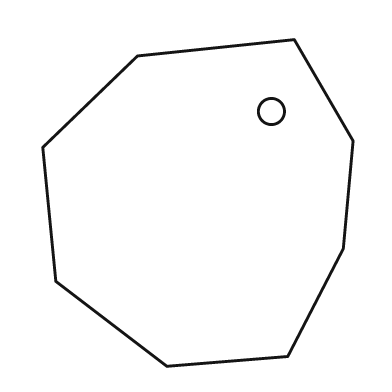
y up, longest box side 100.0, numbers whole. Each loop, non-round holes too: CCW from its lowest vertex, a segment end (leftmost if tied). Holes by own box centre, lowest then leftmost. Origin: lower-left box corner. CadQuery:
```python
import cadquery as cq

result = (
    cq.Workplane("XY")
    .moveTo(38.0, 0.0)
    .lineTo(75.0, 3.0)
    .lineTo(92.0, 36.0)
    .lineTo(95.0, 69.0)
    .lineTo(77.0, 100.0)
    .lineTo(29.0, 95.0)
    .lineTo(0.0, 67.0)
    .lineTo(4.0, 26.0)
    .close()
    .moveTo(70.0, 78.0)
    .circle(4.0)
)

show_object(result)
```